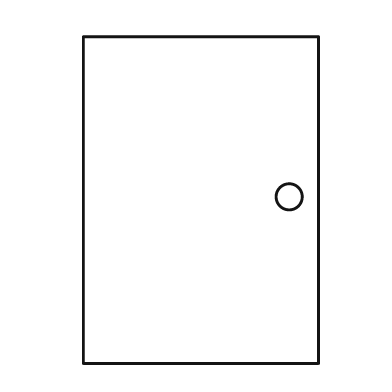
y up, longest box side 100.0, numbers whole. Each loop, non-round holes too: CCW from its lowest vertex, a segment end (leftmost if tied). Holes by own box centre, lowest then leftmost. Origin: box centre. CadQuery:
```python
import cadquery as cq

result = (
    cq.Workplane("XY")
    .moveTo(-36.0, -50.0)
    .lineTo(36.0, -50.0)
    .lineTo(36.0, 50.0)
    .lineTo(-36.0, 50.0)
    .close()
    .moveTo(27.0, 1.0)
    .circle(4.0)
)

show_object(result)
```